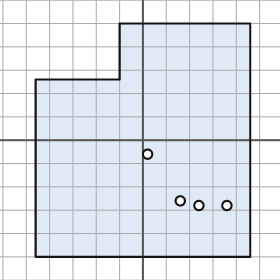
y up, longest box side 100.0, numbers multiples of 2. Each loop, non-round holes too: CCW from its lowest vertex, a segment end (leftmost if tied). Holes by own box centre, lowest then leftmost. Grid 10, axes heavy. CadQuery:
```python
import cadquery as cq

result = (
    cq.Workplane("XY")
    .moveTo(-46.0, -50.0)
    .lineTo(46.0, -50.0)
    .lineTo(46.0, 50.0)
    .lineTo(-10.0, 50.0)
    .lineTo(-10.0, 26.0)
    .lineTo(-46.0, 26.0)
    .close()
    .moveTo(24.0, -28.0)
    .circle(2.0)
    .moveTo(36.0, -28.0)
    .circle(2.0)
    .moveTo(16.0, -26.0)
    .circle(2.0)
    .moveTo(2.0, -6.0)
    .circle(2.0)
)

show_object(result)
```